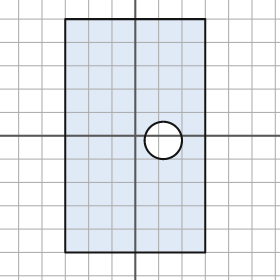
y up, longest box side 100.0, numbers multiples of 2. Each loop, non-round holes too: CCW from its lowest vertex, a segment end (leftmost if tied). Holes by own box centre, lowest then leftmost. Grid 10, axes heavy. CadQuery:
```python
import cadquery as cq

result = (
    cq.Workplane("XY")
    .moveTo(-30.0, -50.0)
    .lineTo(30.0, -50.0)
    .lineTo(30.0, 50.0)
    .lineTo(-30.0, 50.0)
    .close()
    .moveTo(12.0, -2.0)
    .circle(8.0)
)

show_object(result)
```